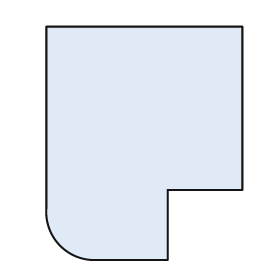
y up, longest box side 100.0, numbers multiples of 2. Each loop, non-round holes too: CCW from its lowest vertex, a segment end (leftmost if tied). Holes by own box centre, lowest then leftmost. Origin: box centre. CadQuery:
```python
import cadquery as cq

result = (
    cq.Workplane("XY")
    .moveTo(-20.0, -50.0)
    .lineTo(10.0, -50.0)
    .lineTo(10.0, -20.0)
    .lineTo(42.0, -20.0)
    .lineTo(42.0, 50.0)
    .lineTo(-42.0, 50.0)
    .lineTo(-42.0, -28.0)
    .threePointArc((-36.0, -44.0), (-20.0, -50.0))
    .close()
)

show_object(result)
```